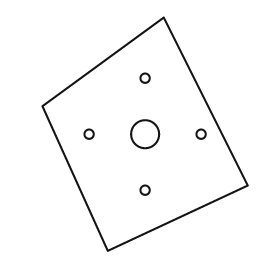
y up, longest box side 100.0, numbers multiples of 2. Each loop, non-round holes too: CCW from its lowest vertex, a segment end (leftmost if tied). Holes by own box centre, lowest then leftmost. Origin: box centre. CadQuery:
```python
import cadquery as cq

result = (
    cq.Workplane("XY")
    .moveTo(-16.0, -50.0)
    .lineTo(44.0, -22.0)
    .lineTo(8.0, 50.0)
    .lineTo(-44.0, 12.0)
    .close()
    .moveTo(0.0, -24.0)
    .circle(2.0)
    .moveTo(-24.0, 0.0)
    .circle(2.0)
    .moveTo(0.0, 0.0)
    .circle(6.0)
    .moveTo(24.0, 0.0)
    .circle(2.0)
    .moveTo(0.0, 24.0)
    .circle(2.0)
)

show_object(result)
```